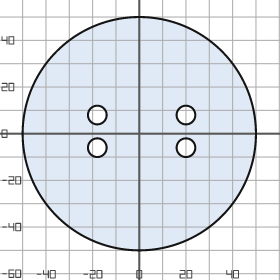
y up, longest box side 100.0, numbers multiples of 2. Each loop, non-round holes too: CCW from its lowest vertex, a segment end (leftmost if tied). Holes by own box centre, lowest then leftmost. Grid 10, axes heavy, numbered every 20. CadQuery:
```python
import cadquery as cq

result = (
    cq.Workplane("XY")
    .moveTo(0.0, 0.0)
    .circle(50.0)
    .moveTo(-18.0, -6.0)
    .circle(4.0)
    .moveTo(20.0, -6.0)
    .circle(4.0)
    .moveTo(-18.0, 8.0)
    .circle(4.0)
    .moveTo(20.0, 8.0)
    .circle(4.0)
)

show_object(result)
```